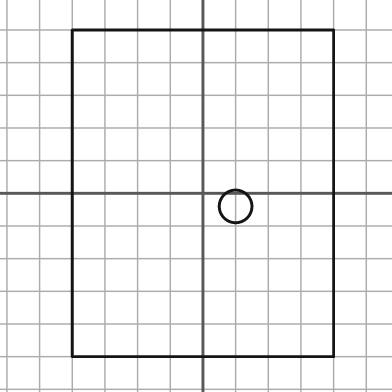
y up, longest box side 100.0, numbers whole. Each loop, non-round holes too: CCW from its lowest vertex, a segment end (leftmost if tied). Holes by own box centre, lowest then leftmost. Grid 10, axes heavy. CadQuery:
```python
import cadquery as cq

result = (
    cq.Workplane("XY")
    .moveTo(-40.0, -50.0)
    .lineTo(40.0, -50.0)
    .lineTo(40.0, 50.0)
    .lineTo(-40.0, 50.0)
    .close()
    .moveTo(10.0, -4.0)
    .circle(5.0)
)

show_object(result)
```